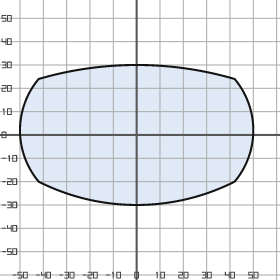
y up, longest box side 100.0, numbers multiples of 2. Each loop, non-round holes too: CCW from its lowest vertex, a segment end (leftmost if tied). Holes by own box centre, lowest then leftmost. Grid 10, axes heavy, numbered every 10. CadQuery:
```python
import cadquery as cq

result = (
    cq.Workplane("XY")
    .moveTo(-42.0, -20.0)
    .threePointArc((0.0, -30.0), (42.0, -20.0))
    .threePointArc((50.0, 2.0), (42.0, 24.0))
    .threePointArc((0.0, 30.0), (-42.0, 24.0))
    .threePointArc((-50.0, 2.0), (-42.0, -20.0))
    .close()
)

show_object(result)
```